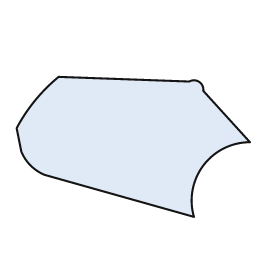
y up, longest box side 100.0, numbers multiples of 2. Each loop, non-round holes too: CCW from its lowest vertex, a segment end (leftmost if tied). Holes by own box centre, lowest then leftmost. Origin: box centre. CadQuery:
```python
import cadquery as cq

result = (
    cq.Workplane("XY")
    .moveTo(26.0, -30.0)
    .threePointArc((30.0, -8.0), (50.0, 2.0))
    .lineTo(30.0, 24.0)
    .threePointArc((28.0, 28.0), (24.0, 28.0))
    .lineTo(-32.0, 30.0)
    .threePointArc((-42.0, 20.0), (-50.0, 8.0))
    .lineTo(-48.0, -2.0)
    .threePointArc((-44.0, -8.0), (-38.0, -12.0))
    .close()
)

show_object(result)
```